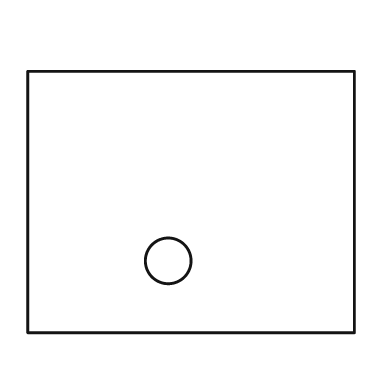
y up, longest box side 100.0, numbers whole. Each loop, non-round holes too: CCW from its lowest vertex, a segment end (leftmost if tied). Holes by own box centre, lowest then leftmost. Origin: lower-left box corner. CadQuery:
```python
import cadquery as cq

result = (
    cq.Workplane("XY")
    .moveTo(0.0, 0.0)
    .lineTo(100.0, 0.0)
    .lineTo(100.0, 80.0)
    .lineTo(0.0, 80.0)
    .close()
    .moveTo(43.0, 22.0)
    .circle(7.0)
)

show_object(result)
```